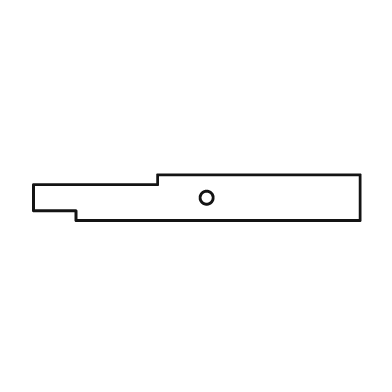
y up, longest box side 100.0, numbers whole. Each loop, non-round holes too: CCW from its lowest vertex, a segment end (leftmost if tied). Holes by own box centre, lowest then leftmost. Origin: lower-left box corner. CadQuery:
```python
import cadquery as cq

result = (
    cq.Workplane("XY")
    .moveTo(13.0, 0.0)
    .lineTo(100.0, 0.0)
    .lineTo(100.0, 14.0)
    .lineTo(38.0, 14.0)
    .lineTo(38.0, 11.0)
    .lineTo(0.0, 11.0)
    .lineTo(0.0, 3.0)
    .lineTo(13.0, 3.0)
    .close()
    .moveTo(53.0, 7.0)
    .circle(2.0)
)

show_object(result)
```